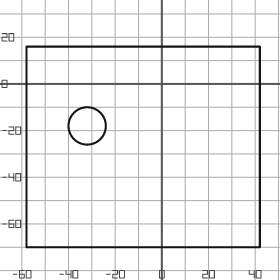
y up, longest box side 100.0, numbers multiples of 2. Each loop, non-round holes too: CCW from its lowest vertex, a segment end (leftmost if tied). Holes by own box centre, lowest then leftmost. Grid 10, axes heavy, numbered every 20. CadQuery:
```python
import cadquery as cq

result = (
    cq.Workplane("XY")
    .moveTo(-58.0, -70.0)
    .lineTo(42.0, -70.0)
    .lineTo(42.0, 16.0)
    .lineTo(-58.0, 16.0)
    .close()
    .moveTo(-32.0, -18.0)
    .circle(8.0)
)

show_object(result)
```